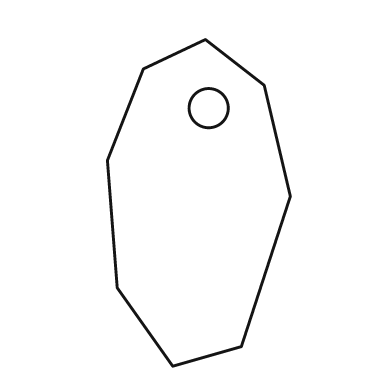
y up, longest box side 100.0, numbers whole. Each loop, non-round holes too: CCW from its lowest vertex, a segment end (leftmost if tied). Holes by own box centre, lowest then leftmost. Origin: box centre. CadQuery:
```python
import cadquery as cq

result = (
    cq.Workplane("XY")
    .moveTo(-8.0, -50.0)
    .lineTo(13.0, -44.0)
    .lineTo(28.0, 2.0)
    .lineTo(20.0, 36.0)
    .lineTo(2.0, 50.0)
    .lineTo(-17.0, 41.0)
    .lineTo(-28.0, 13.0)
    .lineTo(-25.0, -26.0)
    .close()
    .moveTo(3.0, 29.0)
    .circle(6.0)
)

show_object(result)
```